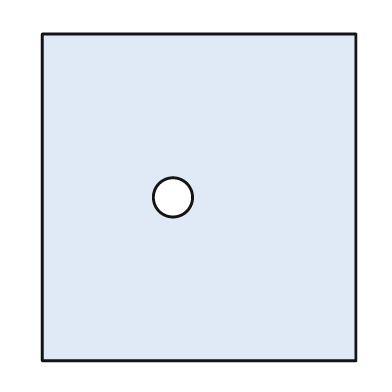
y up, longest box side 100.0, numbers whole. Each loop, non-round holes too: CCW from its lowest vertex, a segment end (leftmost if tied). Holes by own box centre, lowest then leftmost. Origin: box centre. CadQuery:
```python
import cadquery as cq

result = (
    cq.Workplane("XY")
    .moveTo(-48.0, -50.0)
    .lineTo(48.0, -50.0)
    .lineTo(48.0, 50.0)
    .lineTo(-48.0, 50.0)
    .close()
    .moveTo(-8.0, 0.0)
    .circle(6.0)
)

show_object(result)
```